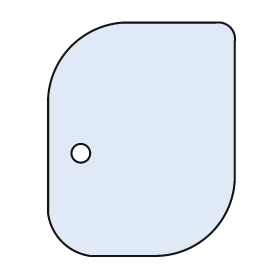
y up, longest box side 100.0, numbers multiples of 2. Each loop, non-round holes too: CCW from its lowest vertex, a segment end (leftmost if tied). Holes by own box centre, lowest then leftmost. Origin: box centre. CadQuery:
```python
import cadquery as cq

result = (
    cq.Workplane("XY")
    .moveTo(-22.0, -50.0)
    .lineTo(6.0, -50.0)
    .threePointArc((30.0, -40.0), (40.0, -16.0))
    .lineTo(40.0, 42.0)
    .threePointArc((38.0, 48.0), (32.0, 50.0))
    .lineTo(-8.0, 50.0)
    .threePointArc((-30.0, 40.0), (-40.0, 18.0))
    .lineTo(-40.0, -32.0)
    .threePointArc((-34.0, -44.0), (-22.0, -50.0))
    .close()
    .moveTo(-26.0, -6.0)
    .circle(4.0)
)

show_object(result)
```